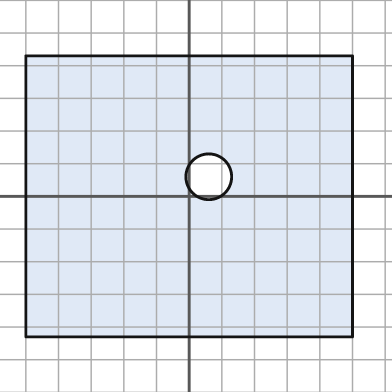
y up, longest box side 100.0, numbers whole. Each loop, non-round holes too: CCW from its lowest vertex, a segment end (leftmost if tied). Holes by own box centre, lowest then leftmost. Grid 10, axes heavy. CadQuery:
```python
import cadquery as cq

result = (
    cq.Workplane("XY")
    .moveTo(-50.0, -43.0)
    .lineTo(50.0, -43.0)
    .lineTo(50.0, 43.0)
    .lineTo(-50.0, 43.0)
    .close()
    .moveTo(6.0, 6.0)
    .circle(7.0)
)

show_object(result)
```